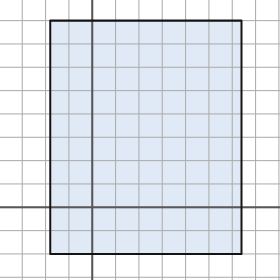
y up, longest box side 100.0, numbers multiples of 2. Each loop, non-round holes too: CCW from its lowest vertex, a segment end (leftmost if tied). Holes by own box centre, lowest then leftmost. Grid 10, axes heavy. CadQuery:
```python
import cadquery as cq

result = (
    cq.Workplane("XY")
    .moveTo(-18.0, -20.0)
    .lineTo(64.0, -20.0)
    .lineTo(64.0, 80.0)
    .lineTo(-18.0, 80.0)
    .close()
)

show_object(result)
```